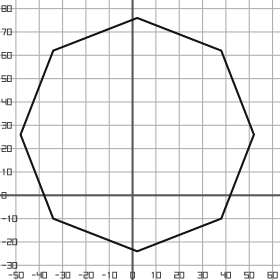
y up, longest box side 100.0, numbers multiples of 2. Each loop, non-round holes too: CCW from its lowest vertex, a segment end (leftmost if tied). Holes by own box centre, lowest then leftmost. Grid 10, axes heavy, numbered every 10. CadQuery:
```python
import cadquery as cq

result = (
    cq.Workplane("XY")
    .moveTo(2.0, -24.0)
    .lineTo(38.0, -10.0)
    .lineTo(52.0, 26.0)
    .lineTo(38.0, 62.0)
    .lineTo(2.0, 76.0)
    .lineTo(-34.0, 62.0)
    .lineTo(-48.0, 26.0)
    .lineTo(-34.0, -10.0)
    .close()
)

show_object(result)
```